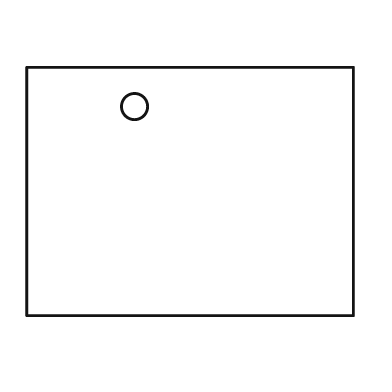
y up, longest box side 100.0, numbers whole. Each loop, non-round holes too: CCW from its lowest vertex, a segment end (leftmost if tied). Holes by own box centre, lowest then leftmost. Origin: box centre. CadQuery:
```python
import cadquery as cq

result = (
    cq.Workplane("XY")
    .moveTo(-50.0, -38.0)
    .lineTo(50.0, -38.0)
    .lineTo(50.0, 38.0)
    .lineTo(-50.0, 38.0)
    .close()
    .moveTo(-17.0, 26.0)
    .circle(4.0)
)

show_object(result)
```